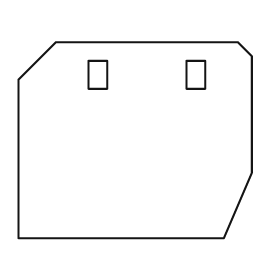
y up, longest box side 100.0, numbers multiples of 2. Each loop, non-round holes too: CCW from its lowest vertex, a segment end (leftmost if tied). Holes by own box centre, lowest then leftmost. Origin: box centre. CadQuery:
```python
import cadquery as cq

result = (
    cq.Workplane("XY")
    .moveTo(-50.0, -42.0)
    .lineTo(38.0, -42.0)
    .lineTo(50.0, -14.0)
    .lineTo(50.0, 36.0)
    .lineTo(44.0, 42.0)
    .lineTo(-34.0, 42.0)
    .lineTo(-50.0, 26.0)
    .close()
    .moveTo(-20.0, 22.0)
    .lineTo(-12.0, 22.0)
    .lineTo(-12.0, 34.0)
    .lineTo(-20.0, 34.0)
    .close()
    .moveTo(22.0, 22.0)
    .lineTo(30.0, 22.0)
    .lineTo(30.0, 34.0)
    .lineTo(22.0, 34.0)
    .close()
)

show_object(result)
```